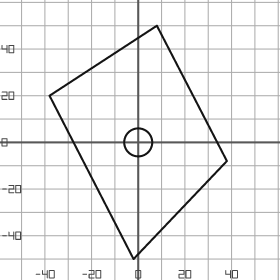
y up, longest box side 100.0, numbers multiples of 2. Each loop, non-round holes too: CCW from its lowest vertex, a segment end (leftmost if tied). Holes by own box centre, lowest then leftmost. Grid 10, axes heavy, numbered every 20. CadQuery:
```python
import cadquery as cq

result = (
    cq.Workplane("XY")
    .moveTo(-2.0, -50.0)
    .lineTo(38.0, -8.0)
    .lineTo(8.0, 50.0)
    .lineTo(-38.0, 20.0)
    .close()
    .moveTo(0.0, 0.0)
    .circle(6.0)
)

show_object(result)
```